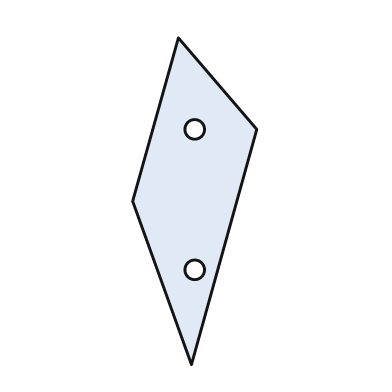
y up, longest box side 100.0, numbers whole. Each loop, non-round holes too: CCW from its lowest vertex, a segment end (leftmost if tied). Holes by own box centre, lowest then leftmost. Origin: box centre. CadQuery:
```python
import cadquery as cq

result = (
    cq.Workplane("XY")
    .moveTo(-1.0, -50.0)
    .lineTo(19.0, 22.0)
    .lineTo(-5.0, 50.0)
    .lineTo(-19.0, 0.0)
    .close()
    .moveTo(0.0, -21.0)
    .circle(3.0)
    .moveTo(0.0, 22.0)
    .circle(3.0)
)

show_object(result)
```